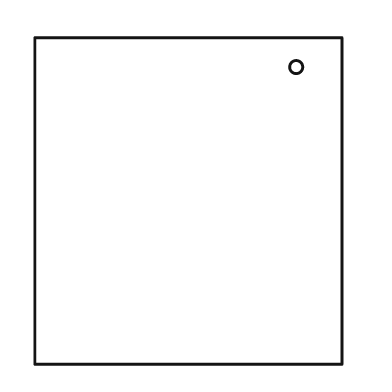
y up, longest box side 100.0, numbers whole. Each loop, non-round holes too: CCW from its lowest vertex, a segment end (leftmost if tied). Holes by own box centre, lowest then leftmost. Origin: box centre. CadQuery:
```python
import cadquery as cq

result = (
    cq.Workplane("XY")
    .moveTo(-47.0, -50.0)
    .lineTo(47.0, -50.0)
    .lineTo(47.0, 50.0)
    .lineTo(-47.0, 50.0)
    .close()
    .moveTo(33.0, 41.0)
    .circle(2.0)
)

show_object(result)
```